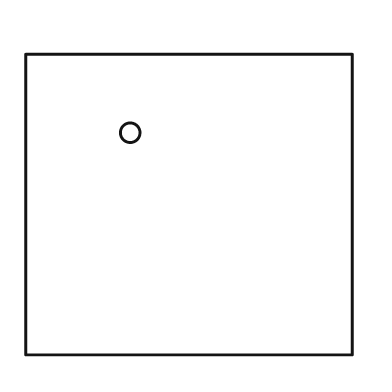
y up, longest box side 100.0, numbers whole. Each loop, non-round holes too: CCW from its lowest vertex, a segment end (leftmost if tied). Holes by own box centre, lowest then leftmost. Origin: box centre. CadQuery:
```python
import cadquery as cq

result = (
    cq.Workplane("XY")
    .moveTo(-50.0, -46.0)
    .lineTo(50.0, -46.0)
    .lineTo(50.0, 46.0)
    .lineTo(-50.0, 46.0)
    .close()
    .moveTo(-18.0, 22.0)
    .circle(3.0)
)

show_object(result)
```